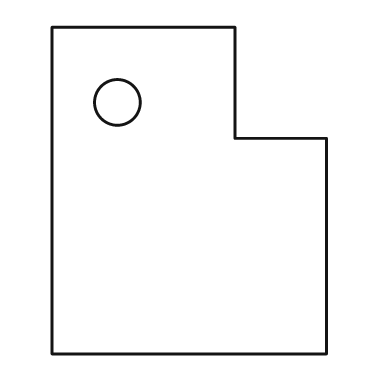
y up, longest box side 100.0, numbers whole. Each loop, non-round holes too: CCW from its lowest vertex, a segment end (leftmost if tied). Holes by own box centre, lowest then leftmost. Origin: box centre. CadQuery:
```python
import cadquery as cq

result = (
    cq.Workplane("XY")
    .moveTo(-42.0, -50.0)
    .lineTo(42.0, -50.0)
    .lineTo(42.0, 16.0)
    .lineTo(14.0, 16.0)
    .lineTo(14.0, 50.0)
    .lineTo(-42.0, 50.0)
    .close()
    .moveTo(-22.0, 27.0)
    .circle(7.0)
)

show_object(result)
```